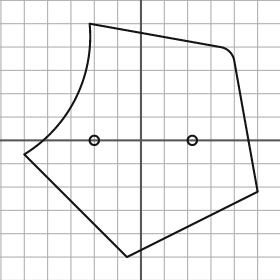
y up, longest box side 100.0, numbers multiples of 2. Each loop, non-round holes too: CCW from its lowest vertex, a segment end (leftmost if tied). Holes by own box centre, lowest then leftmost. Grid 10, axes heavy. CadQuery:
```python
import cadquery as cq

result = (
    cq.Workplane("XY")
    .moveTo(-6.0, -50.0)
    .lineTo(50.0, -22.0)
    .lineTo(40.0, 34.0)
    .threePointArc((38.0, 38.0), (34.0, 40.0))
    .lineTo(-22.0, 50.0)
    .threePointArc((-28.0, 18.0), (-50.0, -6.0))
    .close()
    .moveTo(-20.0, 0.0)
    .circle(2.0)
    .moveTo(22.0, 0.0)
    .circle(2.0)
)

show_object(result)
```